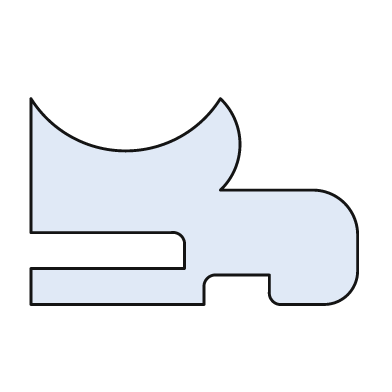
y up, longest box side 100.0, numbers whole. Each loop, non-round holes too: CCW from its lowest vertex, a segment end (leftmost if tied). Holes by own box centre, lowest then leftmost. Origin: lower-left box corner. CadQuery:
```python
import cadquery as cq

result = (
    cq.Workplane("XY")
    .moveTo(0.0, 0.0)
    .lineTo(53.0, 0.0)
    .lineTo(53.0, 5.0)
    .threePointArc((54.0, 8.0), (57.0, 9.0))
    .lineTo(73.0, 9.0)
    .lineTo(73.0, 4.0)
    .threePointArc((74.0, 1.0), (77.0, 0.0))
    .lineTo(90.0, 0.0)
    .threePointArc((97.0, 3.0), (100.0, 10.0))
    .lineTo(100.0, 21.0)
    .threePointArc((96.0, 31.0), (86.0, 35.0))
    .lineTo(58.0, 35.0)
    .threePointArc((64.0, 49.0), (58.0, 63.0))
    .threePointArc((29.0, 47.0), (0.0, 63.0))
    .lineTo(0.0, 22.0)
    .lineTo(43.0, 22.0)
    .threePointArc((46.0, 21.0), (47.0, 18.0))
    .lineTo(47.0, 11.0)
    .lineTo(0.0, 11.0)
    .close()
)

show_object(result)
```